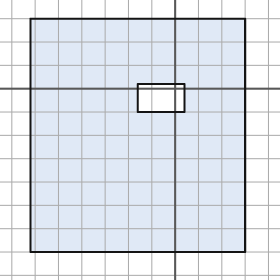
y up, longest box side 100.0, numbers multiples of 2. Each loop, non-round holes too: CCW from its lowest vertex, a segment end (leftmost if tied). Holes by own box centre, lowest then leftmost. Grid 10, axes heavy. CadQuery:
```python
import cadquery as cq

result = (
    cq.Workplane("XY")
    .moveTo(-62.0, -70.0)
    .lineTo(30.0, -70.0)
    .lineTo(30.0, 30.0)
    .lineTo(-62.0, 30.0)
    .close()
    .moveTo(-16.0, -10.0)
    .lineTo(4.0, -10.0)
    .lineTo(4.0, 2.0)
    .lineTo(-16.0, 2.0)
    .close()
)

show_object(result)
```